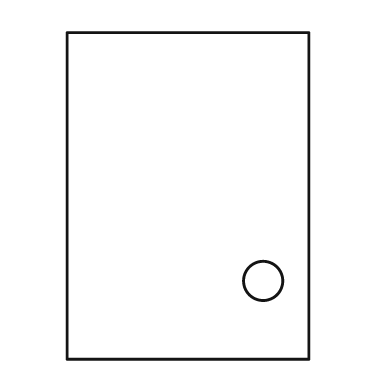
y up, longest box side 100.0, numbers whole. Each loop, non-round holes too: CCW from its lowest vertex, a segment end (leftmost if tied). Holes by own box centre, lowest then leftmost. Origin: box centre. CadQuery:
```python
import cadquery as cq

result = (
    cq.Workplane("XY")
    .moveTo(-37.0, -50.0)
    .lineTo(37.0, -50.0)
    .lineTo(37.0, 50.0)
    .lineTo(-37.0, 50.0)
    .close()
    .moveTo(23.0, -26.0)
    .circle(6.0)
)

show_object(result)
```